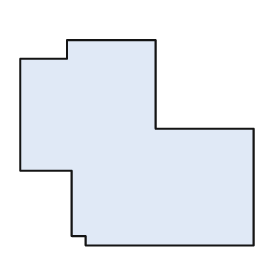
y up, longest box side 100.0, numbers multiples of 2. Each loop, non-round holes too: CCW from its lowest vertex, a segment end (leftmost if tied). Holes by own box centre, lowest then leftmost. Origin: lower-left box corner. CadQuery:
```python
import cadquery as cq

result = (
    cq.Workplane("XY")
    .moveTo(28.0, 0.0)
    .lineTo(100.0, 0.0)
    .lineTo(100.0, 50.0)
    .lineTo(58.0, 50.0)
    .lineTo(58.0, 88.0)
    .lineTo(20.0, 88.0)
    .lineTo(20.0, 80.0)
    .lineTo(0.0, 80.0)
    .lineTo(0.0, 32.0)
    .lineTo(22.0, 32.0)
    .lineTo(22.0, 4.0)
    .lineTo(28.0, 4.0)
    .close()
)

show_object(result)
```